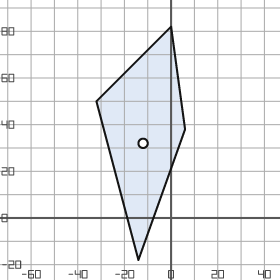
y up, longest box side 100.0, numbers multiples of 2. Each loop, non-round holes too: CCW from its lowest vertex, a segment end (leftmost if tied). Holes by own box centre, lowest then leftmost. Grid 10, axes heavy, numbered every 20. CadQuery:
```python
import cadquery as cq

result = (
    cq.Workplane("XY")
    .moveTo(-14.0, -18.0)
    .lineTo(6.0, 38.0)
    .lineTo(0.0, 82.0)
    .lineTo(-32.0, 50.0)
    .close()
    .moveTo(-12.0, 32.0)
    .circle(2.0)
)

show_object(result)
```